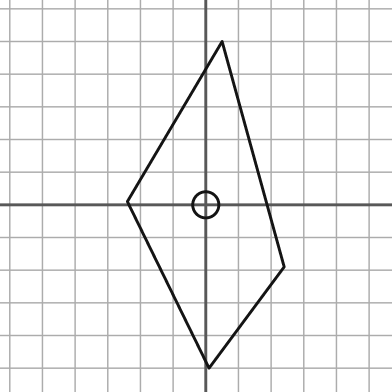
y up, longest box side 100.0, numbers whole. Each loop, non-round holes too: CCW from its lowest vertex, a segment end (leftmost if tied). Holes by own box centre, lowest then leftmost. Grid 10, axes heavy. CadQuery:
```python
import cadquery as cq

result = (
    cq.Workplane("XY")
    .moveTo(1.0, -50.0)
    .lineTo(24.0, -19.0)
    .lineTo(5.0, 50.0)
    .lineTo(-24.0, 1.0)
    .close()
    .moveTo(0.0, 0.0)
    .circle(4.0)
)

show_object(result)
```